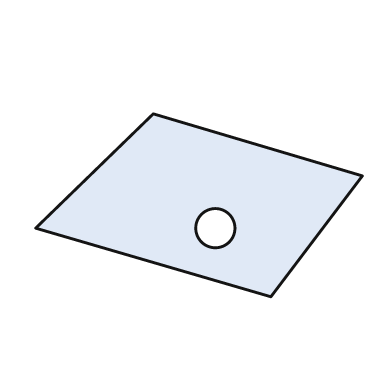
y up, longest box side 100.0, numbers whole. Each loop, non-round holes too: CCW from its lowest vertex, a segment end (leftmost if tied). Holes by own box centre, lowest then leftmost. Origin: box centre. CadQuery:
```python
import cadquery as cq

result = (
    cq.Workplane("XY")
    .moveTo(22.0, -28.0)
    .lineTo(50.0, 9.0)
    .lineTo(-14.0, 28.0)
    .lineTo(-50.0, -7.0)
    .close()
    .moveTo(5.0, -7.0)
    .circle(6.0)
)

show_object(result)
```